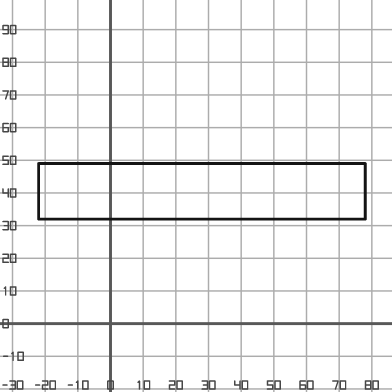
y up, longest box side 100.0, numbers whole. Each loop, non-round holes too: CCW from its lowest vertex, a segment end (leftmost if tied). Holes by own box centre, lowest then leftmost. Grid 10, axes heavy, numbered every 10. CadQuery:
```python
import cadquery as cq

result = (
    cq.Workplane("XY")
    .moveTo(-22.0, 32.0)
    .lineTo(78.0, 32.0)
    .lineTo(78.0, 49.0)
    .lineTo(-22.0, 49.0)
    .close()
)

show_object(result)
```